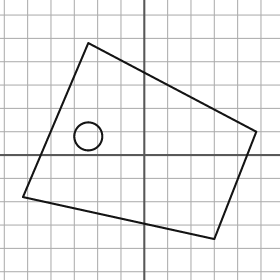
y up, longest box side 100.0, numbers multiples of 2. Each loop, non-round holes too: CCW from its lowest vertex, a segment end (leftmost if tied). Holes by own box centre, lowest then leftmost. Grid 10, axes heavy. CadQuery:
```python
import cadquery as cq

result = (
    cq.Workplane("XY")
    .moveTo(30.0, -36.0)
    .lineTo(48.0, 10.0)
    .lineTo(-24.0, 48.0)
    .lineTo(-52.0, -18.0)
    .close()
    .moveTo(-24.0, 8.0)
    .circle(6.0)
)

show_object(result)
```